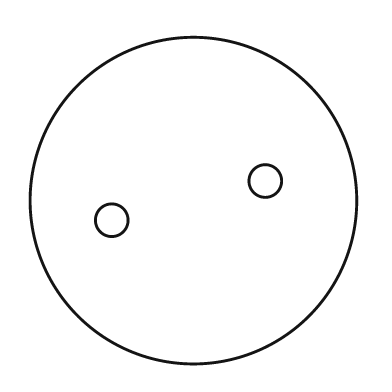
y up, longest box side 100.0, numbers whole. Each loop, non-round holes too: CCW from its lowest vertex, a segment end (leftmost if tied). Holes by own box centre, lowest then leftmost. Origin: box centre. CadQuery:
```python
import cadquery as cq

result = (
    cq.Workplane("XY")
    .moveTo(0.0, 0.0)
    .circle(50.0)
    .moveTo(-25.0, -6.0)
    .circle(5.0)
    .moveTo(22.0, 6.0)
    .circle(5.0)
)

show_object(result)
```